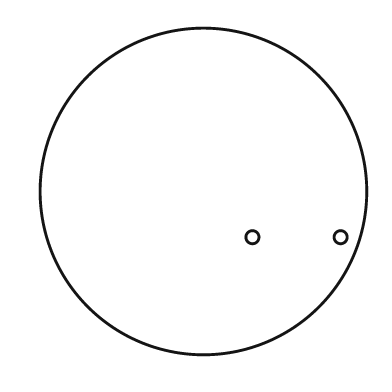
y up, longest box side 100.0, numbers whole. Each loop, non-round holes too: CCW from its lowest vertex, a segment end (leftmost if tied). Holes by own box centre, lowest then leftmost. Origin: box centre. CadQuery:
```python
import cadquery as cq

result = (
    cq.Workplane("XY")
    .moveTo(0.0, 0.0)
    .circle(50.0)
    .moveTo(15.0, -14.0)
    .circle(2.0)
    .moveTo(42.0, -14.0)
    .circle(2.0)
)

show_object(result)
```